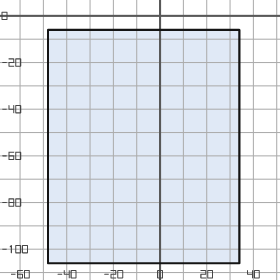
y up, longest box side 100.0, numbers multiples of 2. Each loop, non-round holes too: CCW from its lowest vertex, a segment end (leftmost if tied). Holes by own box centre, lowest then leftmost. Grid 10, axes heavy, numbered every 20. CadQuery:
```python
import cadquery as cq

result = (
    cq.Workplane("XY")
    .moveTo(-48.0, -106.0)
    .lineTo(34.0, -106.0)
    .lineTo(34.0, -6.0)
    .lineTo(-48.0, -6.0)
    .close()
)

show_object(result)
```